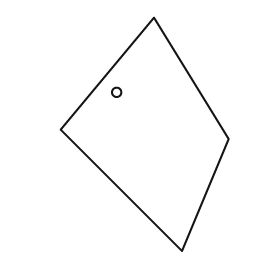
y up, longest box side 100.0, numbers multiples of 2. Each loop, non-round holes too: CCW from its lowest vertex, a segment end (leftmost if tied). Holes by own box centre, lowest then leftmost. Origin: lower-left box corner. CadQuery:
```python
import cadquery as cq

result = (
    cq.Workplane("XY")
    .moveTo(52.0, 0.0)
    .lineTo(72.0, 48.0)
    .lineTo(40.0, 100.0)
    .lineTo(0.0, 52.0)
    .close()
    .moveTo(24.0, 68.0)
    .circle(2.0)
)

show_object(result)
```